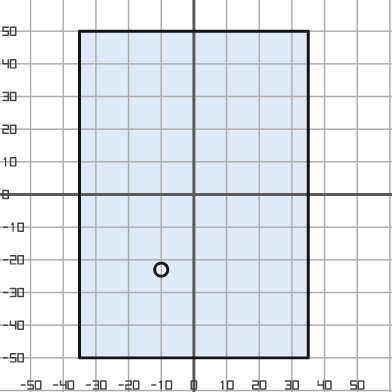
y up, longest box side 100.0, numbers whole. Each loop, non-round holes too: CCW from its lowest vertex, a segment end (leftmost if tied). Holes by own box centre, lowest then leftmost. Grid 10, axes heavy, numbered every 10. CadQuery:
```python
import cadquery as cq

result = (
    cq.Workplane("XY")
    .moveTo(-35.0, -50.0)
    .lineTo(35.0, -50.0)
    .lineTo(35.0, 50.0)
    .lineTo(-35.0, 50.0)
    .close()
    .moveTo(-10.0, -23.0)
    .circle(2.0)
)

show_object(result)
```